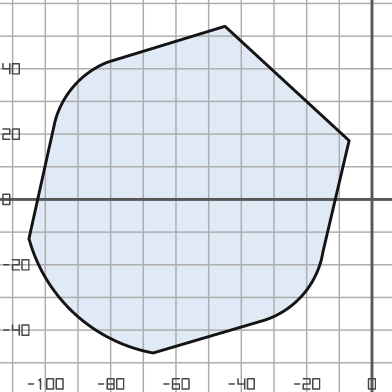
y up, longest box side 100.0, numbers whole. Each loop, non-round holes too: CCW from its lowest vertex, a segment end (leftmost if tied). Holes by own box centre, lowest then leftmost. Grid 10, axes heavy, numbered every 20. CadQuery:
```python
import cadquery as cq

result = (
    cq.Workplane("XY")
    .moveTo(-67.0, -47.0)
    .lineTo(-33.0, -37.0)
    .threePointArc((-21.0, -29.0), (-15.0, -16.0))
    .lineTo(-7.0, 18.0)
    .lineTo(-45.0, 53.0)
    .lineTo(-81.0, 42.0)
    .threePointArc((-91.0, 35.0), (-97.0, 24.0))
    .lineTo(-105.0, -12.0)
    .threePointArc((-91.0, -35.0), (-67.0, -47.0))
    .close()
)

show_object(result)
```